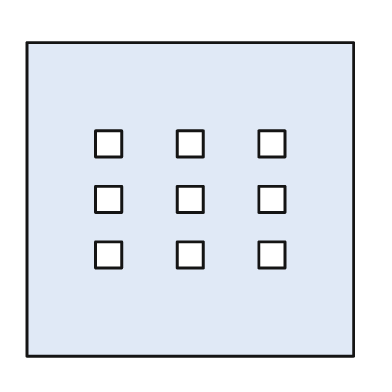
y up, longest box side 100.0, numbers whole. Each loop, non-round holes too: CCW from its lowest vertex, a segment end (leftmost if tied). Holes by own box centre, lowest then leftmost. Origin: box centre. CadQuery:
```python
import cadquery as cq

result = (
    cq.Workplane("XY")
    .moveTo(-50.0, -48.0)
    .lineTo(50.0, -48.0)
    .lineTo(50.0, 48.0)
    .lineTo(-50.0, 48.0)
    .close()
    .moveTo(-29.0, -21.0)
    .lineTo(-21.0, -21.0)
    .lineTo(-21.0, -13.0)
    .lineTo(-29.0, -13.0)
    .close()
    .moveTo(-4.0, -21.0)
    .lineTo(4.0, -21.0)
    .lineTo(4.0, -13.0)
    .lineTo(-4.0, -13.0)
    .close()
    .moveTo(21.0, -21.0)
    .lineTo(29.0, -21.0)
    .lineTo(29.0, -13.0)
    .lineTo(21.0, -13.0)
    .close()
    .moveTo(-29.0, -4.0)
    .lineTo(-21.0, -4.0)
    .lineTo(-21.0, 4.0)
    .lineTo(-29.0, 4.0)
    .close()
    .moveTo(-4.0, -4.0)
    .lineTo(4.0, -4.0)
    .lineTo(4.0, 4.0)
    .lineTo(-4.0, 4.0)
    .close()
    .moveTo(21.0, -4.0)
    .lineTo(29.0, -4.0)
    .lineTo(29.0, 4.0)
    .lineTo(21.0, 4.0)
    .close()
    .moveTo(-29.0, 13.0)
    .lineTo(-21.0, 13.0)
    .lineTo(-21.0, 21.0)
    .lineTo(-29.0, 21.0)
    .close()
    .moveTo(-4.0, 13.0)
    .lineTo(4.0, 13.0)
    .lineTo(4.0, 21.0)
    .lineTo(-4.0, 21.0)
    .close()
    .moveTo(21.0, 13.0)
    .lineTo(29.0, 13.0)
    .lineTo(29.0, 21.0)
    .lineTo(21.0, 21.0)
    .close()
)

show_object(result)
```